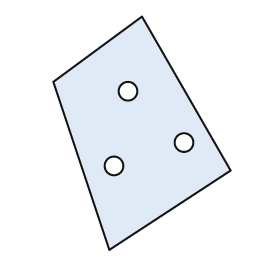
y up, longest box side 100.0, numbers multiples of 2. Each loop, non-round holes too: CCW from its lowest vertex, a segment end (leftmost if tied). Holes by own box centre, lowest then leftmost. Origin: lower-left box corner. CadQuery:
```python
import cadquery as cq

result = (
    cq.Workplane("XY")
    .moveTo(24.0, 0.0)
    .lineTo(76.0, 34.0)
    .lineTo(38.0, 100.0)
    .lineTo(0.0, 72.0)
    .close()
    .moveTo(26.0, 36.0)
    .circle(4.0)
    .moveTo(56.0, 46.0)
    .circle(4.0)
    .moveTo(32.0, 68.0)
    .circle(4.0)
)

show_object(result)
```